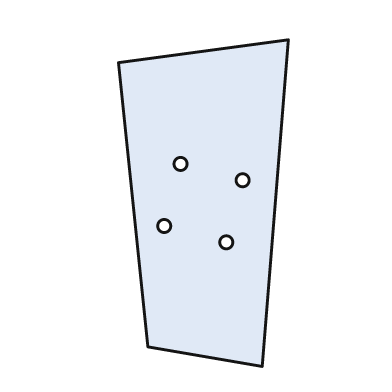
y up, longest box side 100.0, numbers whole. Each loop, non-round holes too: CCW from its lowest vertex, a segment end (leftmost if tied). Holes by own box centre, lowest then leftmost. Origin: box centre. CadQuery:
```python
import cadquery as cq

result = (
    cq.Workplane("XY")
    .moveTo(18.0, -50.0)
    .lineTo(26.0, 50.0)
    .lineTo(-26.0, 43.0)
    .lineTo(-17.0, -44.0)
    .close()
    .moveTo(7.0, -12.0)
    .circle(2.0)
    .moveTo(-12.0, -7.0)
    .circle(2.0)
    .moveTo(12.0, 7.0)
    .circle(2.0)
    .moveTo(-7.0, 12.0)
    .circle(2.0)
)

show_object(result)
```